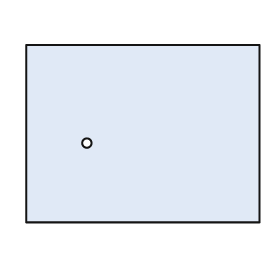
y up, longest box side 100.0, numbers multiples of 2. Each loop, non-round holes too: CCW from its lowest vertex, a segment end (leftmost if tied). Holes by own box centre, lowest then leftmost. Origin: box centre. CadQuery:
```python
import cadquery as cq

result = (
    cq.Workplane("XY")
    .moveTo(-50.0, -38.0)
    .lineTo(50.0, -38.0)
    .lineTo(50.0, 38.0)
    .lineTo(-50.0, 38.0)
    .close()
    .moveTo(-24.0, -4.0)
    .circle(2.0)
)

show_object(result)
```